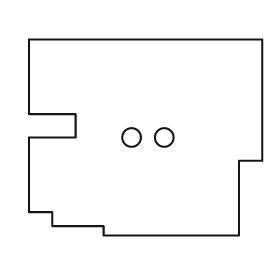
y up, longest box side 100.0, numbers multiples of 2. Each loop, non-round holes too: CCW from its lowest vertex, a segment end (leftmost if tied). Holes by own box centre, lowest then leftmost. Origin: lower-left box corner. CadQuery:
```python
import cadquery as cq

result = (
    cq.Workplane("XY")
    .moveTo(32.0, 0.0)
    .lineTo(90.0, 0.0)
    .lineTo(90.0, 32.0)
    .lineTo(100.0, 32.0)
    .lineTo(100.0, 84.0)
    .lineTo(0.0, 84.0)
    .lineTo(0.0, 52.0)
    .lineTo(20.0, 52.0)
    .lineTo(20.0, 42.0)
    .lineTo(0.0, 42.0)
    .lineTo(0.0, 10.0)
    .lineTo(10.0, 10.0)
    .lineTo(10.0, 4.0)
    .lineTo(32.0, 4.0)
    .close()
    .moveTo(44.0, 42.0)
    .circle(4.0)
    .moveTo(58.0, 42.0)
    .circle(4.0)
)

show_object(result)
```